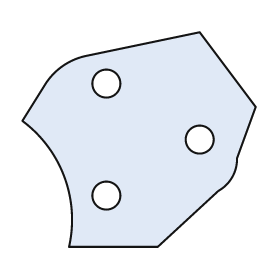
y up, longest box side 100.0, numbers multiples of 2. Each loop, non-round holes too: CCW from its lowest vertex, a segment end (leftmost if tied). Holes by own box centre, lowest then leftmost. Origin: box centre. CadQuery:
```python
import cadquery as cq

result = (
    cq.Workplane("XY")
    .moveTo(-30.0, -46.0)
    .lineTo(8.0, -46.0)
    .lineTo(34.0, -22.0)
    .threePointArc((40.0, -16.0), (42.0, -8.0))
    .lineTo(50.0, 14.0)
    .lineTo(26.0, 46.0)
    .lineTo(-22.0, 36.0)
    .threePointArc((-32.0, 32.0), (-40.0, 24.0))
    .lineTo(-50.0, 8.0)
    .threePointArc((-32.0, -16.0), (-30.0, -46.0))
    .close()
    .moveTo(-14.0, -24.0)
    .circle(6.0)
    .moveTo(26.0, 0.0)
    .circle(6.0)
    .moveTo(-14.0, 24.0)
    .circle(6.0)
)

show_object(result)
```